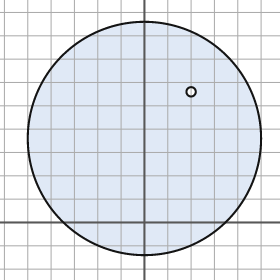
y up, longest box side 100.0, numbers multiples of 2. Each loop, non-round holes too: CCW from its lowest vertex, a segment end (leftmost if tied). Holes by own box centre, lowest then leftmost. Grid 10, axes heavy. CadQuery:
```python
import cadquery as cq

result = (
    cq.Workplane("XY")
    .moveTo(0.0, 36.0)
    .circle(50.0)
    .moveTo(20.0, 56.0)
    .circle(2.0)
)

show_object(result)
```